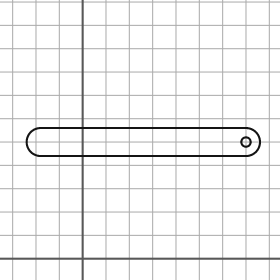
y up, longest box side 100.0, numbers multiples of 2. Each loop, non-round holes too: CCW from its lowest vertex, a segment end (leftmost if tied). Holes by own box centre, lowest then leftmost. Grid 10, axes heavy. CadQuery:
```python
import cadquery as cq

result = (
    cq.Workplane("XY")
    .moveTo(-18.0, 44.0)
    .lineTo(70.0, 44.0)
    .threePointArc((76.0, 50.0), (70.0, 56.0))
    .lineTo(-18.0, 56.0)
    .threePointArc((-24.0, 50.0), (-18.0, 44.0))
    .close()
    .moveTo(70.0, 50.0)
    .circle(2.0)
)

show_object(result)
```